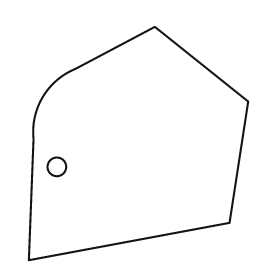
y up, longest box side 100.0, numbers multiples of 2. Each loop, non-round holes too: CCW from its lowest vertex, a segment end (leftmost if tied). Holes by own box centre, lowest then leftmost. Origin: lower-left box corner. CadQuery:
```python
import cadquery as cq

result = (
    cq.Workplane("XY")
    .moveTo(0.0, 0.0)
    .lineTo(86.0, 16.0)
    .lineTo(94.0, 68.0)
    .lineTo(54.0, 100.0)
    .lineTo(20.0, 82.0)
    .threePointArc((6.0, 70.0), (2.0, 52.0))
    .close()
    .moveTo(12.0, 40.0)
    .circle(4.0)
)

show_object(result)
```